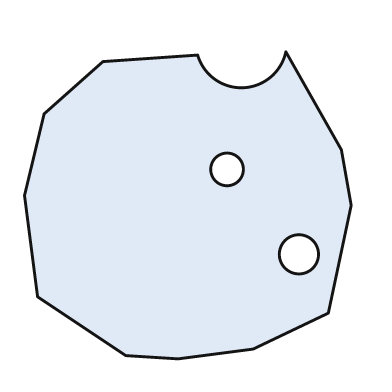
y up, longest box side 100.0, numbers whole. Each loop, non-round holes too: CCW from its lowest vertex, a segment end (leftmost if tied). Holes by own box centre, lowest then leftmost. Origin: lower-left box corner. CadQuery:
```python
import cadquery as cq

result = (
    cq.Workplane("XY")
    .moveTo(47.0, 0.0)
    .lineTo(70.0, 3.0)
    .lineTo(93.0, 14.0)
    .lineTo(100.0, 47.0)
    .lineTo(97.0, 64.0)
    .lineTo(80.0, 94.0)
    .threePointArc((67.0, 83.0), (53.0, 93.0))
    .lineTo(24.0, 91.0)
    .lineTo(6.0, 75.0)
    .lineTo(0.0, 50.0)
    .lineTo(4.0, 19.0)
    .lineTo(31.0, 1.0)
    .close()
    .moveTo(84.0, 32.0)
    .circle(6.0)
    .moveTo(62.0, 58.0)
    .circle(5.0)
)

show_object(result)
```